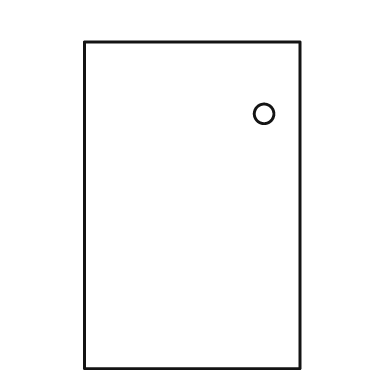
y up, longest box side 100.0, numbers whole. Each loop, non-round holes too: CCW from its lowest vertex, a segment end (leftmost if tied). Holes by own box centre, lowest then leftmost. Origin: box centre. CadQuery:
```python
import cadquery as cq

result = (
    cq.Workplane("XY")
    .moveTo(-33.0, -50.0)
    .lineTo(33.0, -50.0)
    .lineTo(33.0, 50.0)
    .lineTo(-33.0, 50.0)
    .close()
    .moveTo(22.0, 28.0)
    .circle(3.0)
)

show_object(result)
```